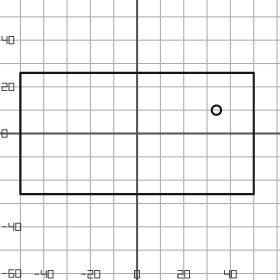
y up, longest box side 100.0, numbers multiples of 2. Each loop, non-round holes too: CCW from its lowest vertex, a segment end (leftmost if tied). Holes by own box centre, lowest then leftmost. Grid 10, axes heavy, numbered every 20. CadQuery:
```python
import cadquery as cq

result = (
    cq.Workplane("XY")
    .moveTo(-50.0, -26.0)
    .lineTo(50.0, -26.0)
    .lineTo(50.0, 26.0)
    .lineTo(-50.0, 26.0)
    .close()
    .moveTo(34.0, 10.0)
    .circle(2.0)
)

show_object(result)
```